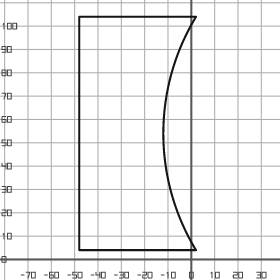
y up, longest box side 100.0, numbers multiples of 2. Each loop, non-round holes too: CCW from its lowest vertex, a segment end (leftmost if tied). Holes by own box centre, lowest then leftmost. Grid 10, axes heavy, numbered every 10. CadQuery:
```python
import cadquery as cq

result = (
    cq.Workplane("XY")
    .moveTo(-48.0, 4.0)
    .lineTo(2.0, 4.0)
    .threePointArc((-12.0, 54.0), (2.0, 104.0))
    .lineTo(-48.0, 104.0)
    .close()
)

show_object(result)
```